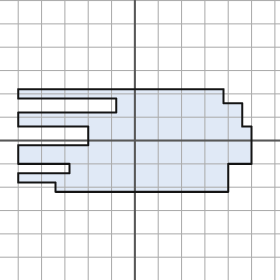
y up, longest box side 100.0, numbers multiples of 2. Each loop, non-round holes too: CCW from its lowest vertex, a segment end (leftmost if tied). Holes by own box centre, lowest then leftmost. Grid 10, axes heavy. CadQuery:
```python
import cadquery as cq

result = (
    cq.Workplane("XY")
    .moveTo(-34.0, -22.0)
    .lineTo(40.0, -22.0)
    .lineTo(40.0, -10.0)
    .lineTo(50.0, -10.0)
    .lineTo(50.0, 6.0)
    .lineTo(46.0, 6.0)
    .lineTo(46.0, 16.0)
    .lineTo(38.0, 16.0)
    .lineTo(38.0, 22.0)
    .lineTo(-50.0, 22.0)
    .lineTo(-50.0, 18.0)
    .lineTo(-8.0, 18.0)
    .lineTo(-8.0, 12.0)
    .lineTo(-50.0, 12.0)
    .lineTo(-50.0, 6.0)
    .lineTo(-20.0, 6.0)
    .lineTo(-20.0, -2.0)
    .lineTo(-50.0, -2.0)
    .lineTo(-50.0, -10.0)
    .lineTo(-28.0, -10.0)
    .lineTo(-28.0, -14.0)
    .lineTo(-50.0, -14.0)
    .lineTo(-50.0, -18.0)
    .lineTo(-34.0, -18.0)
    .close()
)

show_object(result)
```